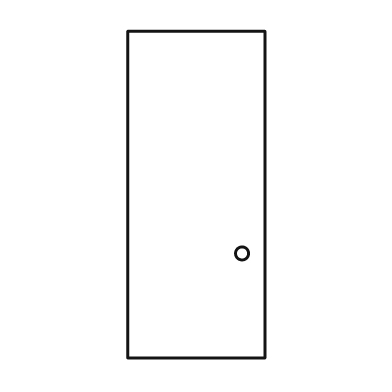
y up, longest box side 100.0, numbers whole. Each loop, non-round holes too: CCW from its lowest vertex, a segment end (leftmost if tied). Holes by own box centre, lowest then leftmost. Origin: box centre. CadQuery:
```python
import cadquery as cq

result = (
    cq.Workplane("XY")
    .moveTo(-21.0, -50.0)
    .lineTo(21.0, -50.0)
    .lineTo(21.0, 50.0)
    .lineTo(-21.0, 50.0)
    .close()
    .moveTo(14.0, -18.0)
    .circle(2.0)
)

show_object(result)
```